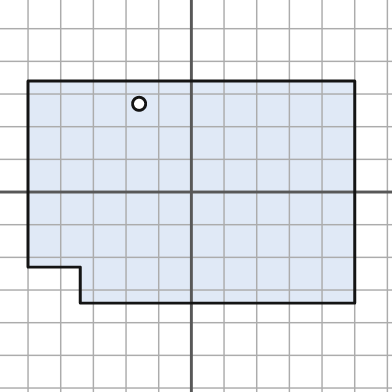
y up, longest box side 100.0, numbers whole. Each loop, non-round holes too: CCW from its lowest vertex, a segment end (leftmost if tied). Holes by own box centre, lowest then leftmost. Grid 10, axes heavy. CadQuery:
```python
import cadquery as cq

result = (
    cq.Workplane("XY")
    .moveTo(-34.0, -34.0)
    .lineTo(50.0, -34.0)
    .lineTo(50.0, 34.0)
    .lineTo(-50.0, 34.0)
    .lineTo(-50.0, -23.0)
    .lineTo(-34.0, -23.0)
    .close()
    .moveTo(-16.0, 27.0)
    .circle(2.0)
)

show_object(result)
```